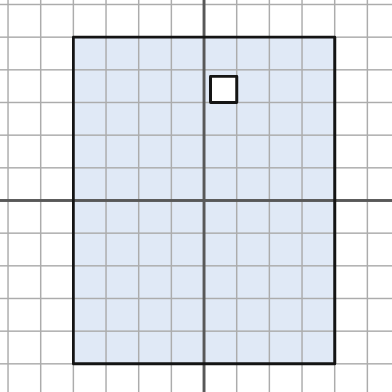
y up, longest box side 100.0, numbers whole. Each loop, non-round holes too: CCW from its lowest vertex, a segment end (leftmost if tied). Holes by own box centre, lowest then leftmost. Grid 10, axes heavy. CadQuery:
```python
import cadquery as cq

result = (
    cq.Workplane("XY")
    .moveTo(-40.0, -50.0)
    .lineTo(40.0, -50.0)
    .lineTo(40.0, 50.0)
    .lineTo(-40.0, 50.0)
    .close()
    .moveTo(2.0, 30.0)
    .lineTo(10.0, 30.0)
    .lineTo(10.0, 38.0)
    .lineTo(2.0, 38.0)
    .close()
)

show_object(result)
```